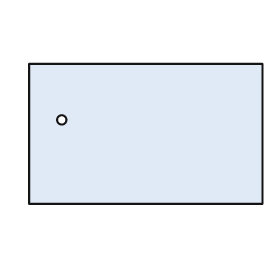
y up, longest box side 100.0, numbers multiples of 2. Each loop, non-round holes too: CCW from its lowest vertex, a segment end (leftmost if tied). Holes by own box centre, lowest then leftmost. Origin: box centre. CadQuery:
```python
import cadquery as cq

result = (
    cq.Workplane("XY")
    .moveTo(-50.0, -30.0)
    .lineTo(50.0, -30.0)
    .lineTo(50.0, 30.0)
    .lineTo(-50.0, 30.0)
    .close()
    .moveTo(-36.0, 6.0)
    .circle(2.0)
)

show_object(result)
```